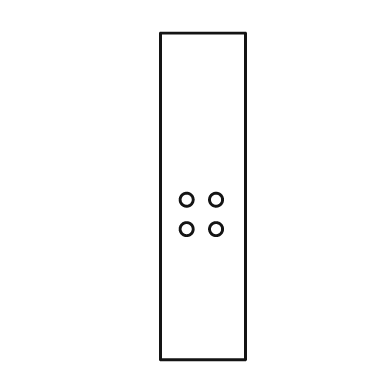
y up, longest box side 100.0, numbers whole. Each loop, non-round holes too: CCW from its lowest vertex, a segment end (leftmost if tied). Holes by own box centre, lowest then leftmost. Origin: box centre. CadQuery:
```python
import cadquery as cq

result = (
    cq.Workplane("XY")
    .moveTo(-13.0, -50.0)
    .lineTo(13.0, -50.0)
    .lineTo(13.0, 50.0)
    .lineTo(-13.0, 50.0)
    .close()
    .moveTo(-5.0, -10.0)
    .circle(2.0)
    .moveTo(4.0, -10.0)
    .circle(2.0)
    .moveTo(-5.0, -1.0)
    .circle(2.0)
    .moveTo(4.0, -1.0)
    .circle(2.0)
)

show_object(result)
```